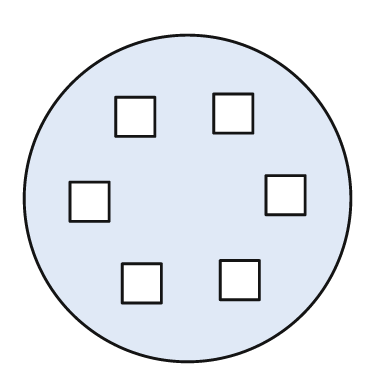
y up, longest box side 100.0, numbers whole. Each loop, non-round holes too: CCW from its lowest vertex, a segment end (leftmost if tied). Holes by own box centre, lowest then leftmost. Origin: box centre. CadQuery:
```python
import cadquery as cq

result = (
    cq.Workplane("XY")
    .moveTo(0.0, 0.0)
    .circle(50.0)
    .moveTo(-20.0, -32.0)
    .lineTo(-8.0, -32.0)
    .lineTo(-8.0, -20.0)
    .lineTo(-20.0, -20.0)
    .close()
    .moveTo(10.0, -31.0)
    .lineTo(22.0, -31.0)
    .lineTo(22.0, -19.0)
    .lineTo(10.0, -19.0)
    .close()
    .moveTo(-36.0, -7.0)
    .lineTo(-24.0, -7.0)
    .lineTo(-24.0, 5.0)
    .lineTo(-36.0, 5.0)
    .close()
    .moveTo(24.0, -5.0)
    .lineTo(36.0, -5.0)
    .lineTo(36.0, 7.0)
    .lineTo(24.0, 7.0)
    .close()
    .moveTo(-22.0, 19.0)
    .lineTo(-10.0, 19.0)
    .lineTo(-10.0, 31.0)
    .lineTo(-22.0, 31.0)
    .close()
    .moveTo(8.0, 20.0)
    .lineTo(20.0, 20.0)
    .lineTo(20.0, 32.0)
    .lineTo(8.0, 32.0)
    .close()
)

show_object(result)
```